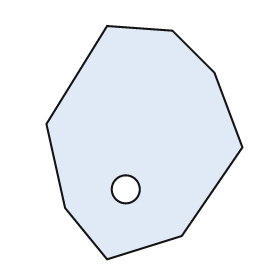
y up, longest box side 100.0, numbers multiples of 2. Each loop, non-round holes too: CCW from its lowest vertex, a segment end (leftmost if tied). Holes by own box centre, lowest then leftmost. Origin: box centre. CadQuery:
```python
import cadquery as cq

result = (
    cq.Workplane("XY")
    .moveTo(-16.0, -50.0)
    .lineTo(16.0, -40.0)
    .lineTo(42.0, -2.0)
    .lineTo(30.0, 30.0)
    .lineTo(12.0, 48.0)
    .lineTo(-16.0, 50.0)
    .lineTo(-42.0, 8.0)
    .lineTo(-34.0, -28.0)
    .close()
    .moveTo(-8.0, -20.0)
    .circle(6.0)
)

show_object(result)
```